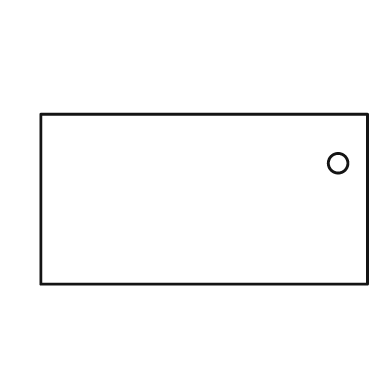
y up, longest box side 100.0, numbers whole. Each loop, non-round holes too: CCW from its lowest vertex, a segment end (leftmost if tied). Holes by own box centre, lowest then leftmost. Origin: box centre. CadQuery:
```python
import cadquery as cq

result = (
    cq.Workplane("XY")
    .moveTo(-50.0, -26.0)
    .lineTo(50.0, -26.0)
    .lineTo(50.0, 26.0)
    .lineTo(-50.0, 26.0)
    .close()
    .moveTo(41.0, 11.0)
    .circle(3.0)
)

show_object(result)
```